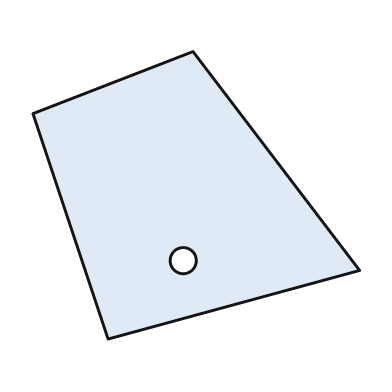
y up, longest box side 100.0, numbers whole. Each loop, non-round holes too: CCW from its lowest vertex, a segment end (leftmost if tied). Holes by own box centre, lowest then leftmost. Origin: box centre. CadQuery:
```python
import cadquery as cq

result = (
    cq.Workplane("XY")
    .moveTo(-27.0, -44.0)
    .lineTo(50.0, -23.0)
    .lineTo(-1.0, 44.0)
    .lineTo(-50.0, 25.0)
    .close()
    .moveTo(-4.0, -20.0)
    .circle(4.0)
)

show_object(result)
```